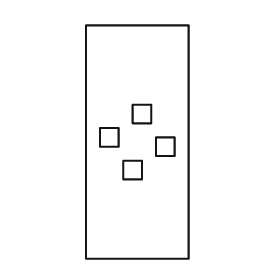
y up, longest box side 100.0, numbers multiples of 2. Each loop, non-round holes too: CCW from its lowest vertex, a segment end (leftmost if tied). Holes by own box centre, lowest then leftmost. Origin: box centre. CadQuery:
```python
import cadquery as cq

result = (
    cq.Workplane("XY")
    .moveTo(-22.0, -50.0)
    .lineTo(22.0, -50.0)
    .lineTo(22.0, 50.0)
    .lineTo(-22.0, 50.0)
    .close()
    .moveTo(-6.0, -16.0)
    .lineTo(2.0, -16.0)
    .lineTo(2.0, -8.0)
    .lineTo(-6.0, -8.0)
    .close()
    .moveTo(8.0, -6.0)
    .lineTo(16.0, -6.0)
    .lineTo(16.0, 2.0)
    .lineTo(8.0, 2.0)
    .close()
    .moveTo(-16.0, -2.0)
    .lineTo(-8.0, -2.0)
    .lineTo(-8.0, 6.0)
    .lineTo(-16.0, 6.0)
    .close()
    .moveTo(-2.0, 8.0)
    .lineTo(6.0, 8.0)
    .lineTo(6.0, 16.0)
    .lineTo(-2.0, 16.0)
    .close()
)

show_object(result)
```